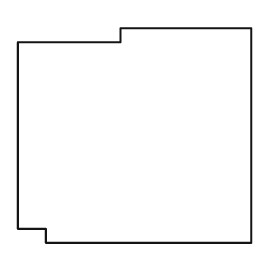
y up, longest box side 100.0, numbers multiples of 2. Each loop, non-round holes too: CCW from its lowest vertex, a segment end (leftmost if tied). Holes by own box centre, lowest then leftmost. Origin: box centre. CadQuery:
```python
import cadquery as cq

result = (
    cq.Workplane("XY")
    .moveTo(-38.0, -46.0)
    .lineTo(50.0, -46.0)
    .lineTo(50.0, 46.0)
    .lineTo(-6.0, 46.0)
    .lineTo(-6.0, 40.0)
    .lineTo(-50.0, 40.0)
    .lineTo(-50.0, -40.0)
    .lineTo(-38.0, -40.0)
    .close()
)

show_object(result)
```